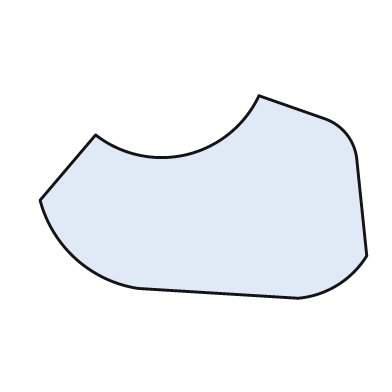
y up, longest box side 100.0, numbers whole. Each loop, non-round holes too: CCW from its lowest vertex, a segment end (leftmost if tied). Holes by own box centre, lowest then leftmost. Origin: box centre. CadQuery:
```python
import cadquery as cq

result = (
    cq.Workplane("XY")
    .moveTo(29.0, -31.0)
    .threePointArc((41.0, -27.0), (50.0, -18.0))
    .lineTo(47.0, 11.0)
    .threePointArc((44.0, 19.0), (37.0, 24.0))
    .lineTo(17.0, 31.0)
    .threePointArc((-5.0, 13.0), (-33.0, 19.0))
    .lineTo(-50.0, -1.0)
    .threePointArc((-39.0, -19.0), (-20.0, -28.0))
    .close()
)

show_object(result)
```